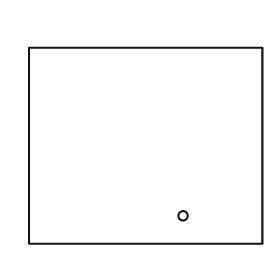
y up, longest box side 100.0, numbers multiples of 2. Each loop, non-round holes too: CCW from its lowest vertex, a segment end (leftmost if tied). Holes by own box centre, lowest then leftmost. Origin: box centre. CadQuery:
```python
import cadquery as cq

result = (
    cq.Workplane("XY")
    .moveTo(-50.0, -42.0)
    .lineTo(50.0, -42.0)
    .lineTo(50.0, 42.0)
    .lineTo(-50.0, 42.0)
    .close()
    .moveTo(16.0, -30.0)
    .circle(2.0)
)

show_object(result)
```